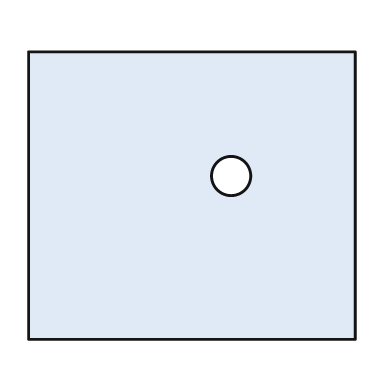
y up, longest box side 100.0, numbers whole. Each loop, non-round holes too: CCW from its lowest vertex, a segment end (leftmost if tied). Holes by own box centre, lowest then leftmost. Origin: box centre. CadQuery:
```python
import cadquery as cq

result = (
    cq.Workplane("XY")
    .moveTo(-50.0, -44.0)
    .lineTo(50.0, -44.0)
    .lineTo(50.0, 44.0)
    .lineTo(-50.0, 44.0)
    .close()
    .moveTo(12.0, 6.0)
    .circle(6.0)
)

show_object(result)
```